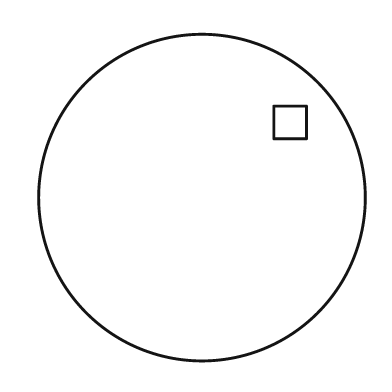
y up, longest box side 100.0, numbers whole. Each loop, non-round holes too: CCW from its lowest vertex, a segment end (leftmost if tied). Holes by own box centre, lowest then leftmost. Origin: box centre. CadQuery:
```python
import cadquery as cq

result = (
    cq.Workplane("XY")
    .moveTo(0.0, 0.0)
    .circle(50.0)
    .moveTo(22.0, 18.0)
    .lineTo(32.0, 18.0)
    .lineTo(32.0, 28.0)
    .lineTo(22.0, 28.0)
    .close()
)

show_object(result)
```